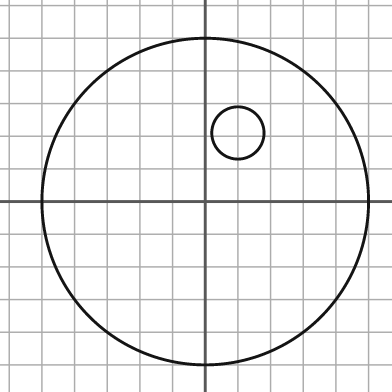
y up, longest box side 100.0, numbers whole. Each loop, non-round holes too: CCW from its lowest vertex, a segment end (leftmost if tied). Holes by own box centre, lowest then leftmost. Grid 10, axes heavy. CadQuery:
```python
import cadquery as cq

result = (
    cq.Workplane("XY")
    .moveTo(0.0, 0.0)
    .circle(50.0)
    .moveTo(10.0, 21.0)
    .circle(8.0)
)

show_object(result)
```